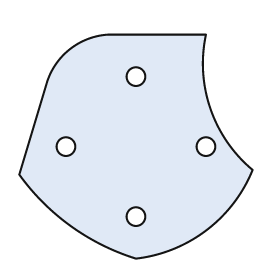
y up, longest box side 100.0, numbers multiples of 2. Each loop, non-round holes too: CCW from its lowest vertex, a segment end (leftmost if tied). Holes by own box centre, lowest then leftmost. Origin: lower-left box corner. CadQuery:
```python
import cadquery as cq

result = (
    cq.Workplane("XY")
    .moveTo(50.0, 0.0)
    .threePointArc((80.0, 12.0), (100.0, 38.0))
    .threePointArc((82.0, 64.0), (80.0, 96.0))
    .lineTo(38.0, 96.0)
    .threePointArc((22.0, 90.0), (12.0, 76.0))
    .lineTo(0.0, 36.0)
    .threePointArc((22.0, 14.0), (50.0, 0.0))
    .close()
    .moveTo(50.0, 18.0)
    .circle(4.0)
    .moveTo(20.0, 48.0)
    .circle(4.0)
    .moveTo(80.0, 48.0)
    .circle(4.0)
    .moveTo(50.0, 78.0)
    .circle(4.0)
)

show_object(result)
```